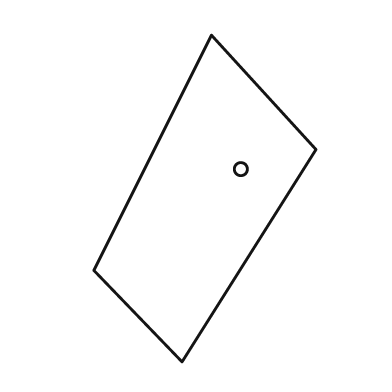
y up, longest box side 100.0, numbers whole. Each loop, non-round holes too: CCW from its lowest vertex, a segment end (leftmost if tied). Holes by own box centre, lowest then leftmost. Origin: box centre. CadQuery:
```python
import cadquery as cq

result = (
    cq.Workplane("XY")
    .moveTo(-7.0, -50.0)
    .lineTo(34.0, 15.0)
    .lineTo(2.0, 50.0)
    .lineTo(-34.0, -22.0)
    .close()
    .moveTo(11.0, 9.0)
    .circle(2.0)
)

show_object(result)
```